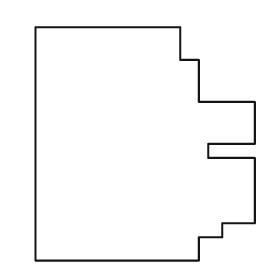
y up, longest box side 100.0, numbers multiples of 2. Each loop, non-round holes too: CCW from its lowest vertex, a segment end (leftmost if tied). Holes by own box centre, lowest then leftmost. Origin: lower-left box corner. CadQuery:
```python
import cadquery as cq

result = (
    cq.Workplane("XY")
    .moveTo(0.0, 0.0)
    .lineTo(70.0, 0.0)
    .lineTo(70.0, 10.0)
    .lineTo(80.0, 10.0)
    .lineTo(80.0, 16.0)
    .lineTo(94.0, 16.0)
    .lineTo(94.0, 44.0)
    .lineTo(74.0, 44.0)
    .lineTo(74.0, 50.0)
    .lineTo(94.0, 50.0)
    .lineTo(94.0, 68.0)
    .lineTo(70.0, 68.0)
    .lineTo(70.0, 86.0)
    .lineTo(62.0, 86.0)
    .lineTo(62.0, 100.0)
    .lineTo(0.0, 100.0)
    .close()
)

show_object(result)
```